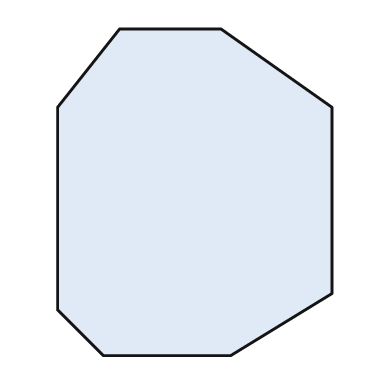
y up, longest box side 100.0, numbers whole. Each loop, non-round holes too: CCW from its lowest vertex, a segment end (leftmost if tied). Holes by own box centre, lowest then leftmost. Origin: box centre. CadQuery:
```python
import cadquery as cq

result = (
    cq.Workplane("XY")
    .moveTo(-28.0, -50.0)
    .lineTo(11.0, -50.0)
    .lineTo(42.0, -31.0)
    .lineTo(42.0, 26.0)
    .lineTo(8.0, 50.0)
    .lineTo(-23.0, 50.0)
    .lineTo(-42.0, 26.0)
    .lineTo(-42.0, -36.0)
    .close()
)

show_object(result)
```